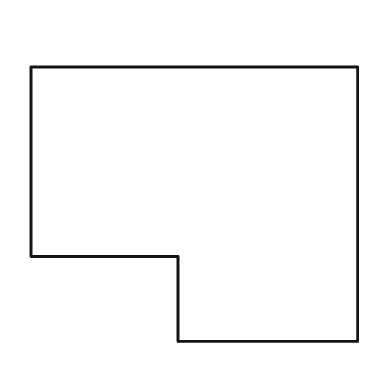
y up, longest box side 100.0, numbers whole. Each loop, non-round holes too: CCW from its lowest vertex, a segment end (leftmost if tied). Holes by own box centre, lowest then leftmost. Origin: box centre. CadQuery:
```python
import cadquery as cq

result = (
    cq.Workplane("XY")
    .moveTo(-5.0, -42.0)
    .lineTo(50.0, -42.0)
    .lineTo(50.0, 42.0)
    .lineTo(-50.0, 42.0)
    .lineTo(-50.0, -16.0)
    .lineTo(-5.0, -16.0)
    .close()
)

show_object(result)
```